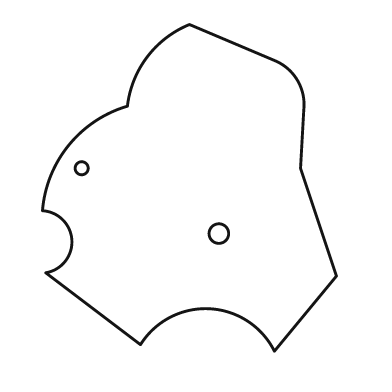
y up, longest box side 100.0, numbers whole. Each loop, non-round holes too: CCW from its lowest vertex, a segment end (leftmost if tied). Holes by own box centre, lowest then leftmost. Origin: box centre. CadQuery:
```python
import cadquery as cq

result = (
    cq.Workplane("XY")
    .moveTo(26.0, -50.0)
    .lineTo(45.0, -27.0)
    .lineTo(34.0, 6.0)
    .lineTo(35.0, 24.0)
    .threePointArc((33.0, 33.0), (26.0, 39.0))
    .lineTo(0.0, 50.0)
    .threePointArc((-13.0, 40.0), (-19.0, 25.0))
    .threePointArc((-37.0, 13.0), (-45.0, -7.0))
    .threePointArc((-36.0, -16.0), (-44.0, -26.0))
    .lineTo(-15.0, -48.0)
    .threePointArc((6.0, -37.0), (26.0, -50.0))
    .close()
    .moveTo(9.0, -14.0)
    .circle(3.0)
    .moveTo(-33.0, 6.0)
    .circle(2.0)
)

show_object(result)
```